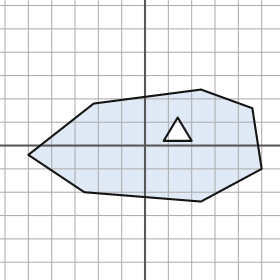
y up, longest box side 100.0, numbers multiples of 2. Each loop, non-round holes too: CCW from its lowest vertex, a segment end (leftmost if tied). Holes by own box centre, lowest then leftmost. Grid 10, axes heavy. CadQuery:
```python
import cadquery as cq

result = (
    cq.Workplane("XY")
    .moveTo(24.0, -24.0)
    .lineTo(50.0, -10.0)
    .lineTo(46.0, 16.0)
    .lineTo(24.0, 24.0)
    .lineTo(-22.0, 18.0)
    .lineTo(-50.0, -4.0)
    .lineTo(-26.0, -20.0)
    .close()
    .moveTo(8.0, 2.0)
    .lineTo(20.0, 2.0)
    .lineTo(14.0, 12.0)
    .close()
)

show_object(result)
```